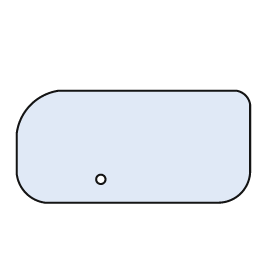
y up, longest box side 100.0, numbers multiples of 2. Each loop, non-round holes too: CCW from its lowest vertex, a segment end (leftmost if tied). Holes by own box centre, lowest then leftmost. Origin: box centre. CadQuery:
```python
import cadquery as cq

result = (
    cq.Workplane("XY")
    .moveTo(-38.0, -24.0)
    .lineTo(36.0, -24.0)
    .threePointArc((46.0, -20.0), (50.0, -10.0))
    .lineTo(50.0, 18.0)
    .threePointArc((48.0, 22.0), (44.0, 24.0))
    .lineTo(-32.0, 24.0)
    .threePointArc((-44.0, 18.0), (-50.0, 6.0))
    .lineTo(-50.0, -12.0)
    .threePointArc((-46.0, -20.0), (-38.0, -24.0))
    .close()
    .moveTo(-14.0, -14.0)
    .circle(2.0)
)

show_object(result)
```